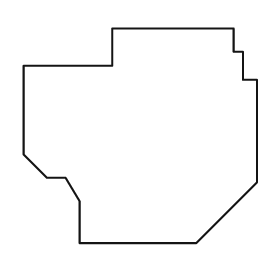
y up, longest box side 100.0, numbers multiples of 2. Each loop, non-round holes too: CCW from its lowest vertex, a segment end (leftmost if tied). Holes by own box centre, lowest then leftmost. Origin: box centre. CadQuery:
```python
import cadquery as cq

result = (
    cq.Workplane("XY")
    .moveTo(-26.0, -46.0)
    .lineTo(24.0, -46.0)
    .lineTo(50.0, -20.0)
    .lineTo(50.0, 24.0)
    .lineTo(44.0, 24.0)
    .lineTo(44.0, 36.0)
    .lineTo(40.0, 36.0)
    .lineTo(40.0, 46.0)
    .lineTo(-12.0, 46.0)
    .lineTo(-12.0, 30.0)
    .lineTo(-50.0, 30.0)
    .lineTo(-50.0, -8.0)
    .lineTo(-40.0, -18.0)
    .lineTo(-32.0, -18.0)
    .lineTo(-26.0, -28.0)
    .close()
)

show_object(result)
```